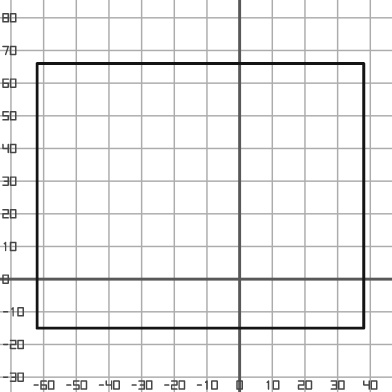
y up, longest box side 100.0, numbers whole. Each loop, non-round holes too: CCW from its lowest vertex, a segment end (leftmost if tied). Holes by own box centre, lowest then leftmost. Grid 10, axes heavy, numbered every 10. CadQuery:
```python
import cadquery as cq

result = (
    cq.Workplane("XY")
    .moveTo(-62.0, -15.0)
    .lineTo(38.0, -15.0)
    .lineTo(38.0, 66.0)
    .lineTo(-62.0, 66.0)
    .close()
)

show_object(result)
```